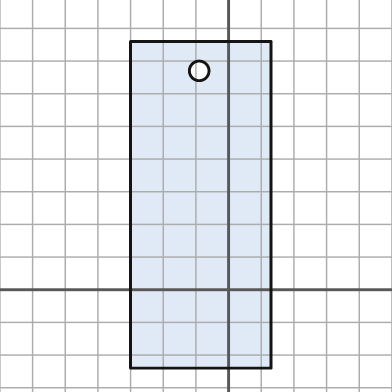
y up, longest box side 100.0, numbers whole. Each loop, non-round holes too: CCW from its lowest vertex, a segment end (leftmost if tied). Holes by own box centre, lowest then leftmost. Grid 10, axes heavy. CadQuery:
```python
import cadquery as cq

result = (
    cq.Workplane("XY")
    .moveTo(-30.0, -24.0)
    .lineTo(13.0, -24.0)
    .lineTo(13.0, 76.0)
    .lineTo(-30.0, 76.0)
    .close()
    .moveTo(-9.0, 67.0)
    .circle(3.0)
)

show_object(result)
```